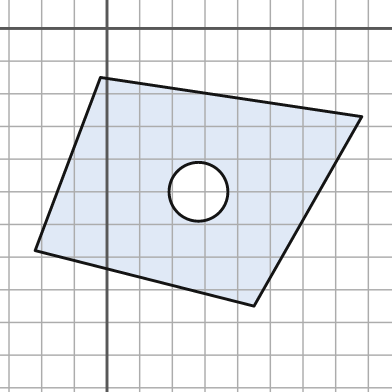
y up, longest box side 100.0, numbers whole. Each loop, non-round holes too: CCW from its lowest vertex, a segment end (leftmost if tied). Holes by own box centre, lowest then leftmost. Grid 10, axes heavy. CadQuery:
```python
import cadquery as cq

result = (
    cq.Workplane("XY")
    .moveTo(45.0, -85.0)
    .lineTo(78.0, -27.0)
    .lineTo(-2.0, -15.0)
    .lineTo(-22.0, -68.0)
    .close()
    .moveTo(28.0, -50.0)
    .circle(9.0)
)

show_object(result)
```